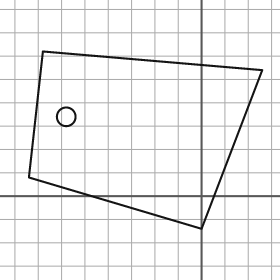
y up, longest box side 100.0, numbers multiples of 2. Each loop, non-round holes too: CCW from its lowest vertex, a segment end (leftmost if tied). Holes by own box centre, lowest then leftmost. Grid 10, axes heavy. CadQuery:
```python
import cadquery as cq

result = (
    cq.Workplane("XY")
    .moveTo(0.0, -14.0)
    .lineTo(26.0, 54.0)
    .lineTo(-68.0, 62.0)
    .lineTo(-74.0, 8.0)
    .close()
    .moveTo(-58.0, 34.0)
    .circle(4.0)
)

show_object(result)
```